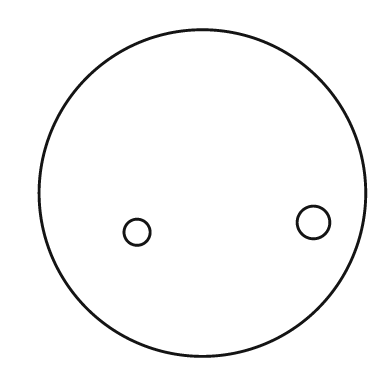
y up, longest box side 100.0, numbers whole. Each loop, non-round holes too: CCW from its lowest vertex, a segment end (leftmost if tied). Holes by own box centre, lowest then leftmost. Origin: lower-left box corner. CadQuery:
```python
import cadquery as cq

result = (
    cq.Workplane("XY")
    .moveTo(50.0, 50.0)
    .circle(50.0)
    .moveTo(30.0, 38.0)
    .circle(4.0)
    .moveTo(84.0, 41.0)
    .circle(5.0)
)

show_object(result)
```